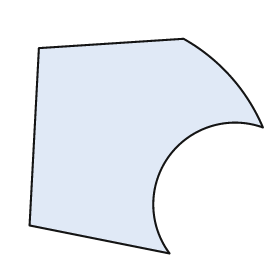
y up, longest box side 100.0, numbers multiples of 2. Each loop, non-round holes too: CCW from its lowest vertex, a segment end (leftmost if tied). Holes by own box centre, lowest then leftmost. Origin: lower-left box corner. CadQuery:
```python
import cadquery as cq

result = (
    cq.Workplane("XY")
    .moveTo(60.0, 0.0)
    .threePointArc((60.0, 42.0), (100.0, 54.0))
    .threePointArc((86.0, 76.0), (66.0, 92.0))
    .lineTo(4.0, 88.0)
    .lineTo(0.0, 12.0)
    .close()
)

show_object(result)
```